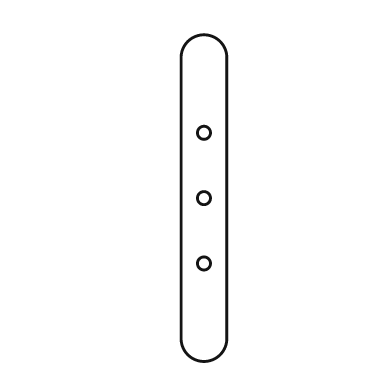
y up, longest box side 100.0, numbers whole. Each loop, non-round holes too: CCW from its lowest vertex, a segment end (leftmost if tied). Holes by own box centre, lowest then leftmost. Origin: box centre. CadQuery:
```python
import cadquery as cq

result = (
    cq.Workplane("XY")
    .moveTo(-7.0, -43.0)
    .threePointArc((0.0, -50.0), (7.0, -43.0))
    .lineTo(7.0, 43.0)
    .threePointArc((0.0, 50.0), (-7.0, 43.0))
    .close()
    .moveTo(0.0, -20.0)
    .circle(2.0)
    .moveTo(0.0, 0.0)
    .circle(2.0)
    .moveTo(0.0, 20.0)
    .circle(2.0)
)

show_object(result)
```